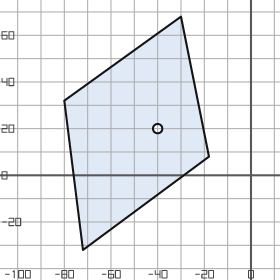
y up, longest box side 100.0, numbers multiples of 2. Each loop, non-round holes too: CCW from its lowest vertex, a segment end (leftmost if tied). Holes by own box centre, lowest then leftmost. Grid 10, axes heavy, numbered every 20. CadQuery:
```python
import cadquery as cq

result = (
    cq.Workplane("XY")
    .moveTo(-72.0, -32.0)
    .lineTo(-18.0, 8.0)
    .lineTo(-30.0, 68.0)
    .lineTo(-80.0, 32.0)
    .close()
    .moveTo(-40.0, 20.0)
    .circle(2.0)
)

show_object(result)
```